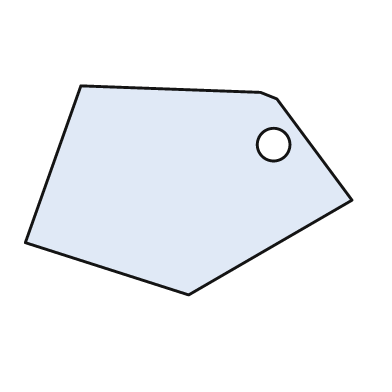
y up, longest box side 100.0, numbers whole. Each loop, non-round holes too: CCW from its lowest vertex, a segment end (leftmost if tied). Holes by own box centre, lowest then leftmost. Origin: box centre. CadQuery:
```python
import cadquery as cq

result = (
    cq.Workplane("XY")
    .moveTo(0.0, -32.0)
    .lineTo(50.0, -3.0)
    .lineTo(27.0, 28.0)
    .lineTo(22.0, 30.0)
    .lineTo(-33.0, 32.0)
    .lineTo(-50.0, -16.0)
    .close()
    .moveTo(26.0, 14.0)
    .circle(5.0)
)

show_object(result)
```